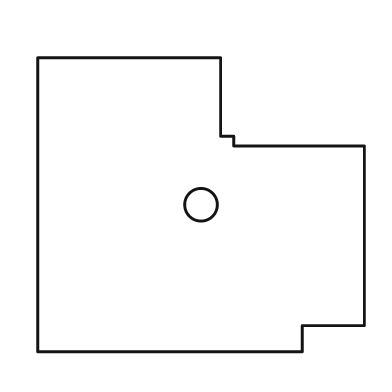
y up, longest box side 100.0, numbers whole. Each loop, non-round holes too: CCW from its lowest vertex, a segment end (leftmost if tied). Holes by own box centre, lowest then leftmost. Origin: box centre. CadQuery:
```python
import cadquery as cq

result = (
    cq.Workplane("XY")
    .moveTo(-50.0, -45.0)
    .lineTo(31.0, -45.0)
    .lineTo(31.0, -37.0)
    .lineTo(50.0, -37.0)
    .lineTo(50.0, 18.0)
    .lineTo(10.0, 18.0)
    .lineTo(10.0, 21.0)
    .lineTo(6.0, 21.0)
    .lineTo(6.0, 45.0)
    .lineTo(-50.0, 45.0)
    .close()
    .moveTo(0.0, 0.0)
    .circle(5.0)
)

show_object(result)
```